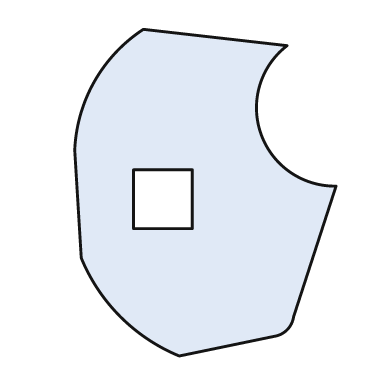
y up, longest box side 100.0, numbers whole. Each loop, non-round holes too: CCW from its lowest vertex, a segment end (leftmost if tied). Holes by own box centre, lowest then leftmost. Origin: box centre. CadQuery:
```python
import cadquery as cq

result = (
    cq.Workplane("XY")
    .moveTo(-8.0, -50.0)
    .lineTo(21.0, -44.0)
    .threePointArc((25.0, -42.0), (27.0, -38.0))
    .lineTo(40.0, 2.0)
    .threePointArc((17.0, 18.0), (25.0, 45.0))
    .lineTo(-19.0, 50.0)
    .threePointArc((-34.0, 34.0), (-40.0, 13.0))
    .lineTo(-38.0, -20.0)
    .threePointArc((-26.0, -38.0), (-8.0, -50.0))
    .close()
    .moveTo(-22.0, -11.0)
    .lineTo(-4.0, -11.0)
    .lineTo(-4.0, 7.0)
    .lineTo(-22.0, 7.0)
    .close()
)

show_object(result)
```